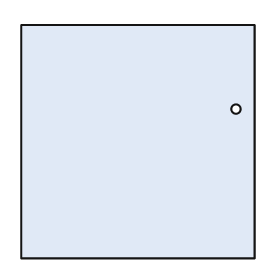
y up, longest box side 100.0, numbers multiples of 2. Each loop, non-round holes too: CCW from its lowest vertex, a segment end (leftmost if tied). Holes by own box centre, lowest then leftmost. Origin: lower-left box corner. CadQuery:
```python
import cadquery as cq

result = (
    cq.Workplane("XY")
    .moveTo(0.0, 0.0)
    .lineTo(100.0, 0.0)
    .lineTo(100.0, 100.0)
    .lineTo(0.0, 100.0)
    .close()
    .moveTo(92.0, 64.0)
    .circle(2.0)
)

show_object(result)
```